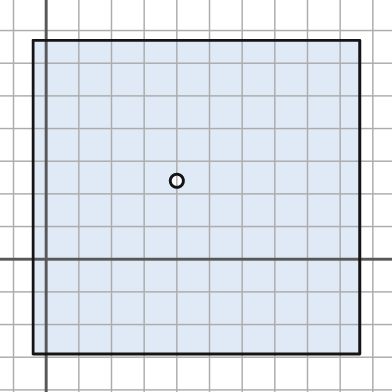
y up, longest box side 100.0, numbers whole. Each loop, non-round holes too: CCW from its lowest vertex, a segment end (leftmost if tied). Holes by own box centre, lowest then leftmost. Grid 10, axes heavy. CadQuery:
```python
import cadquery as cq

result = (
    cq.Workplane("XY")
    .moveTo(-4.0, -29.0)
    .lineTo(96.0, -29.0)
    .lineTo(96.0, 67.0)
    .lineTo(-4.0, 67.0)
    .close()
    .moveTo(40.0, 24.0)
    .circle(2.0)
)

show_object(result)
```